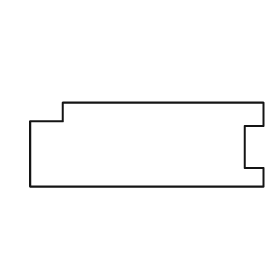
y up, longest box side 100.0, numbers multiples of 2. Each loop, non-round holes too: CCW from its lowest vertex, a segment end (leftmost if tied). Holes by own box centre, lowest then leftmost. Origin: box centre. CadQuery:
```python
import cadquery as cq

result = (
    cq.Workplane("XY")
    .moveTo(-50.0, -18.0)
    .lineTo(50.0, -18.0)
    .lineTo(50.0, -10.0)
    .lineTo(42.0, -10.0)
    .lineTo(42.0, 8.0)
    .lineTo(50.0, 8.0)
    .lineTo(50.0, 18.0)
    .lineTo(-36.0, 18.0)
    .lineTo(-36.0, 10.0)
    .lineTo(-50.0, 10.0)
    .close()
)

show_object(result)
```